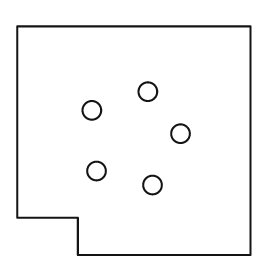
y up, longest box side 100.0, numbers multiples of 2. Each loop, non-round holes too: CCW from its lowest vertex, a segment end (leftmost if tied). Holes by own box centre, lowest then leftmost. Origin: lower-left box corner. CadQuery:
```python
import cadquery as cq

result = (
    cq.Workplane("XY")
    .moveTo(26.0, 0.0)
    .lineTo(100.0, 0.0)
    .lineTo(100.0, 98.0)
    .lineTo(0.0, 98.0)
    .lineTo(0.0, 16.0)
    .lineTo(26.0, 16.0)
    .close()
    .moveTo(58.0, 30.0)
    .circle(4.0)
    .moveTo(34.0, 36.0)
    .circle(4.0)
    .moveTo(70.0, 52.0)
    .circle(4.0)
    .moveTo(32.0, 62.0)
    .circle(4.0)
    .moveTo(56.0, 70.0)
    .circle(4.0)
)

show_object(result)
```